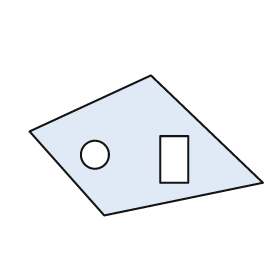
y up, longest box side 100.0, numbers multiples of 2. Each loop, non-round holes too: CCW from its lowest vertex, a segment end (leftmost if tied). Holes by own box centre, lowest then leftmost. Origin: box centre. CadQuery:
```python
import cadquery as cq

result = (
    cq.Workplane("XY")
    .moveTo(-18.0, -30.0)
    .lineTo(50.0, -16.0)
    .lineTo(2.0, 30.0)
    .lineTo(-50.0, 6.0)
    .close()
    .moveTo(6.0, -16.0)
    .lineTo(18.0, -16.0)
    .lineTo(18.0, 4.0)
    .lineTo(6.0, 4.0)
    .close()
    .moveTo(-22.0, -4.0)
    .circle(6.0)
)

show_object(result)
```